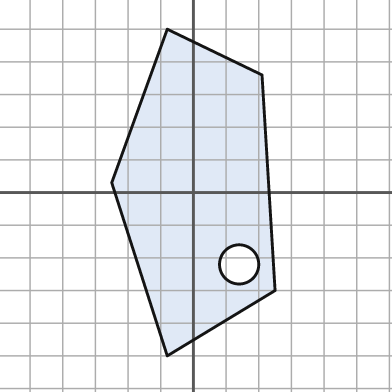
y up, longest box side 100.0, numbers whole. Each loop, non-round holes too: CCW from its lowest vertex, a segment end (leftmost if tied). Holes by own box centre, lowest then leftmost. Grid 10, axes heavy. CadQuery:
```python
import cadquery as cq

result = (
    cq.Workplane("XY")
    .moveTo(-8.0, -50.0)
    .lineTo(25.0, -30.0)
    .lineTo(21.0, 36.0)
    .lineTo(-8.0, 50.0)
    .lineTo(-25.0, 3.0)
    .close()
    .moveTo(14.0, -22.0)
    .circle(6.0)
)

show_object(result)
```